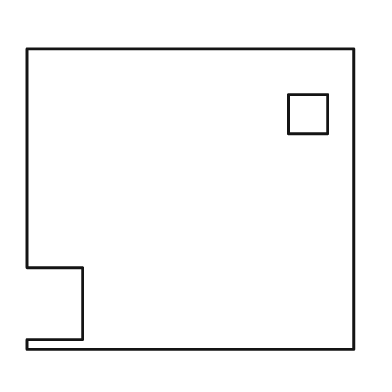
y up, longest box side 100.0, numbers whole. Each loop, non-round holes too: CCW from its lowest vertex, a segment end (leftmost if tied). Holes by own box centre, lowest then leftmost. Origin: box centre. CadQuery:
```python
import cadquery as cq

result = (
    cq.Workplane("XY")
    .moveTo(-50.0, -46.0)
    .lineTo(50.0, -46.0)
    .lineTo(50.0, 46.0)
    .lineTo(-50.0, 46.0)
    .lineTo(-50.0, -21.0)
    .lineTo(-33.0, -21.0)
    .lineTo(-33.0, -43.0)
    .lineTo(-50.0, -43.0)
    .close()
    .moveTo(30.0, 20.0)
    .lineTo(42.0, 20.0)
    .lineTo(42.0, 32.0)
    .lineTo(30.0, 32.0)
    .close()
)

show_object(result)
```